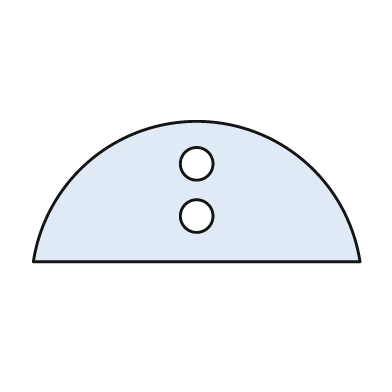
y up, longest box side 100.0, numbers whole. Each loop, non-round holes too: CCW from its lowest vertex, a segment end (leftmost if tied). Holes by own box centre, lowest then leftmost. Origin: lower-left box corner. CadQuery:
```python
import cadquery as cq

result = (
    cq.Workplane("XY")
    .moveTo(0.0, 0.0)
    .lineTo(100.0, 0.0)
    .threePointArc((50.0, 43.0), (0.0, 0.0))
    .close()
    .moveTo(50.0, 14.0)
    .circle(5.0)
    .moveTo(50.0, 30.0)
    .circle(5.0)
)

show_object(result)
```